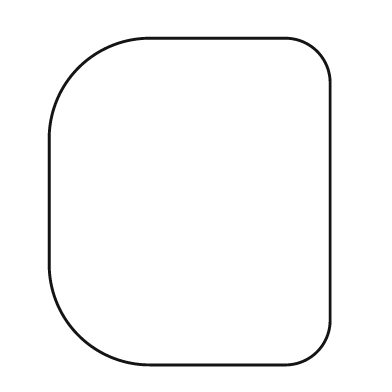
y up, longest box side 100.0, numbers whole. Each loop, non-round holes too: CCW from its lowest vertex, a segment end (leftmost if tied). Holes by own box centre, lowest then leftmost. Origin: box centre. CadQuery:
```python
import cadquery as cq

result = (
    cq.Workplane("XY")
    .moveTo(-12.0, -50.0)
    .lineTo(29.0, -50.0)
    .threePointArc((39.0, -46.0), (43.0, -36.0))
    .lineTo(43.0, 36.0)
    .threePointArc((39.0, 46.0), (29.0, 50.0))
    .lineTo(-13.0, 50.0)
    .threePointArc((-34.0, 41.0), (-43.0, 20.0))
    .lineTo(-43.0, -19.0)
    .threePointArc((-34.0, -41.0), (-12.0, -50.0))
    .close()
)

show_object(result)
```